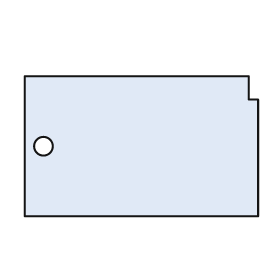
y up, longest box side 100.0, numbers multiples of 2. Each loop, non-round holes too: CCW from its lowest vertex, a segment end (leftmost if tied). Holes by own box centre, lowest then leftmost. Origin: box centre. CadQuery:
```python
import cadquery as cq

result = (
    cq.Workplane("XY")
    .moveTo(-50.0, -30.0)
    .lineTo(50.0, -30.0)
    .lineTo(50.0, 20.0)
    .lineTo(46.0, 20.0)
    .lineTo(46.0, 30.0)
    .lineTo(-50.0, 30.0)
    .close()
    .moveTo(-42.0, 0.0)
    .circle(4.0)
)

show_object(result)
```